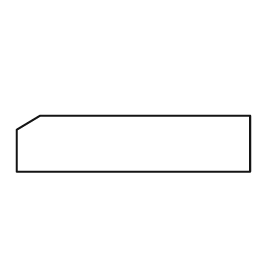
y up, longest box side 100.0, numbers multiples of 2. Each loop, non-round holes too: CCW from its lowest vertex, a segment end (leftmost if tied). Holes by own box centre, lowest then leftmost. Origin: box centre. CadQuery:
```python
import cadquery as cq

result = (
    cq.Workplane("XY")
    .moveTo(-50.0, -12.0)
    .lineTo(50.0, -12.0)
    .lineTo(50.0, 12.0)
    .lineTo(-40.0, 12.0)
    .lineTo(-50.0, 6.0)
    .close()
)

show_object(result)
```